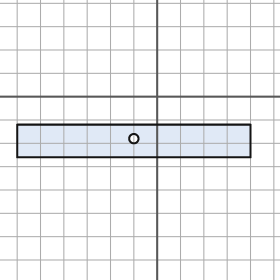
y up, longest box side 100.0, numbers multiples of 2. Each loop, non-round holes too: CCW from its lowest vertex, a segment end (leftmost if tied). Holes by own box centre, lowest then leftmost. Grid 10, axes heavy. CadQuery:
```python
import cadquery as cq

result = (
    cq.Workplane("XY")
    .moveTo(-60.0, -26.0)
    .lineTo(40.0, -26.0)
    .lineTo(40.0, -12.0)
    .lineTo(-60.0, -12.0)
    .close()
    .moveTo(-10.0, -18.0)
    .circle(2.0)
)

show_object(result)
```